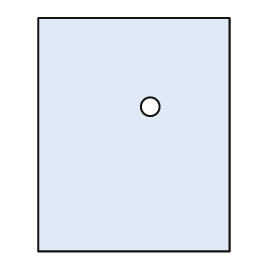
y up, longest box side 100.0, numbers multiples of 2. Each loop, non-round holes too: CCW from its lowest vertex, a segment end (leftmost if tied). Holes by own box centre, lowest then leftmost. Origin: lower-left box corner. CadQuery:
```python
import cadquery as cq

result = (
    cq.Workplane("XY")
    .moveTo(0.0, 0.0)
    .lineTo(82.0, 0.0)
    .lineTo(82.0, 100.0)
    .lineTo(0.0, 100.0)
    .close()
    .moveTo(48.0, 62.0)
    .circle(4.0)
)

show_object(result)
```